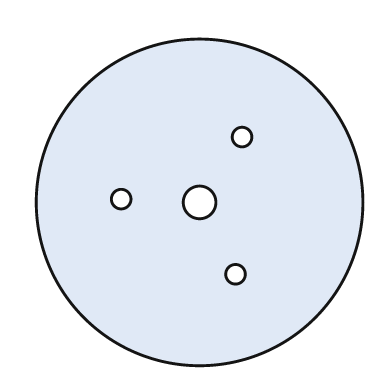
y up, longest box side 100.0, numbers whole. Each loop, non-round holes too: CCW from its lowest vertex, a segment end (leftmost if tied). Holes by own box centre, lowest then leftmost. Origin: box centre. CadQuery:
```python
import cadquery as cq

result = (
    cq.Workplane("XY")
    .moveTo(0.0, 0.0)
    .circle(50.0)
    .moveTo(11.0, -22.0)
    .circle(3.0)
    .moveTo(0.0, 0.0)
    .circle(5.0)
    .moveTo(-24.0, 1.0)
    .circle(3.0)
    .moveTo(13.0, 20.0)
    .circle(3.0)
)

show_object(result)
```